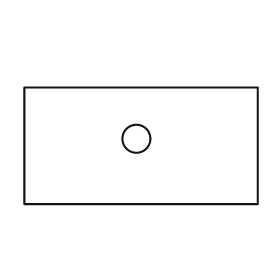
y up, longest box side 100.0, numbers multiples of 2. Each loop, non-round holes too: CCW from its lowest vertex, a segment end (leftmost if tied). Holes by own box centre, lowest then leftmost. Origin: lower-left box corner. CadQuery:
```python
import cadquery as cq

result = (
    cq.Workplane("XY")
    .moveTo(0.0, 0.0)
    .lineTo(100.0, 0.0)
    .lineTo(100.0, 50.0)
    .lineTo(0.0, 50.0)
    .close()
    .moveTo(48.0, 28.0)
    .circle(6.0)
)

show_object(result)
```